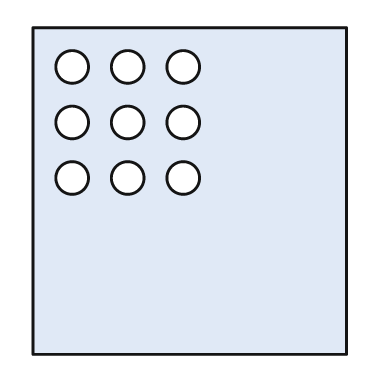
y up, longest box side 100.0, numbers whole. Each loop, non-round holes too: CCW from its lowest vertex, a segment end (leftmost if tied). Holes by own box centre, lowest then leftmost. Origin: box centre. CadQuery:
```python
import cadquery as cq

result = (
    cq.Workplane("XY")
    .moveTo(-48.0, -50.0)
    .lineTo(48.0, -50.0)
    .lineTo(48.0, 50.0)
    .lineTo(-48.0, 50.0)
    .close()
    .moveTo(-36.0, 4.0)
    .circle(5.0)
    .moveTo(-19.0, 4.0)
    .circle(5.0)
    .moveTo(-2.0, 4.0)
    .circle(5.0)
    .moveTo(-36.0, 21.0)
    .circle(5.0)
    .moveTo(-19.0, 21.0)
    .circle(5.0)
    .moveTo(-2.0, 21.0)
    .circle(5.0)
    .moveTo(-36.0, 38.0)
    .circle(5.0)
    .moveTo(-19.0, 38.0)
    .circle(5.0)
    .moveTo(-2.0, 38.0)
    .circle(5.0)
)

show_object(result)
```